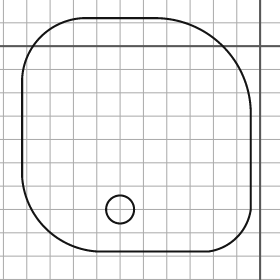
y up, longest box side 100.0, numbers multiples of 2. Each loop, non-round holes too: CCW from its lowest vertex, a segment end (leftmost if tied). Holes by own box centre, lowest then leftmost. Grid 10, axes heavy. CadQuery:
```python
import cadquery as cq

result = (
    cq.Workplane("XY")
    .moveTo(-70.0, -88.0)
    .lineTo(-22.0, -88.0)
    .threePointArc((-10.0, -82.0), (-4.0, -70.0))
    .lineTo(-4.0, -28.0)
    .threePointArc((-16.0, 0.0), (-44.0, 12.0))
    .lineTo(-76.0, 12.0)
    .threePointArc((-94.0, 4.0), (-102.0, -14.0))
    .lineTo(-102.0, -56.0)
    .threePointArc((-92.0, -78.0), (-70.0, -88.0))
    .close()
    .moveTo(-60.0, -70.0)
    .circle(6.0)
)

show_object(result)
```